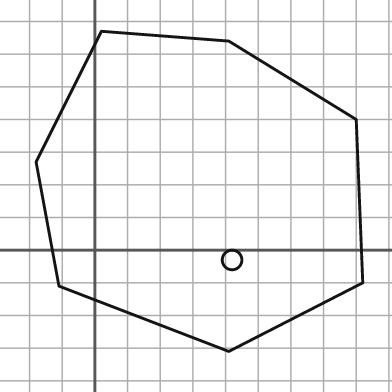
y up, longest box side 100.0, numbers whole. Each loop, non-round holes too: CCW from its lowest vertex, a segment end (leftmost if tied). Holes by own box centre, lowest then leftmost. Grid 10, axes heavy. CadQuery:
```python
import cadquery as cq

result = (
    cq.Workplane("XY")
    .moveTo(41.0, -31.0)
    .lineTo(82.0, -10.0)
    .lineTo(80.0, 40.0)
    .lineTo(41.0, 64.0)
    .lineTo(2.0, 67.0)
    .lineTo(-18.0, 27.0)
    .lineTo(-11.0, -11.0)
    .close()
    .moveTo(42.0, -3.0)
    .circle(3.0)
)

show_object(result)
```